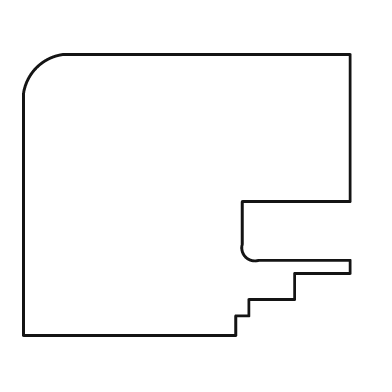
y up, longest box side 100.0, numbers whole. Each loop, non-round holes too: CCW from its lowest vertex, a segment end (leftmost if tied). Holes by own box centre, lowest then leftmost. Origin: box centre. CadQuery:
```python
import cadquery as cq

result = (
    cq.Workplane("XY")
    .moveTo(-50.0, -43.0)
    .lineTo(15.0, -43.0)
    .lineTo(15.0, -37.0)
    .lineTo(19.0, -37.0)
    .lineTo(19.0, -32.0)
    .lineTo(33.0, -32.0)
    .lineTo(33.0, -24.0)
    .lineTo(50.0, -24.0)
    .lineTo(50.0, -20.0)
    .lineTo(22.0, -20.0)
    .threePointArc((18.0, -19.0), (17.0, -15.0))
    .lineTo(17.0, -2.0)
    .lineTo(50.0, -2.0)
    .lineTo(50.0, 43.0)
    .lineTo(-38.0, 43.0)
    .threePointArc((-46.0, 39.0), (-50.0, 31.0))
    .close()
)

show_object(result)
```